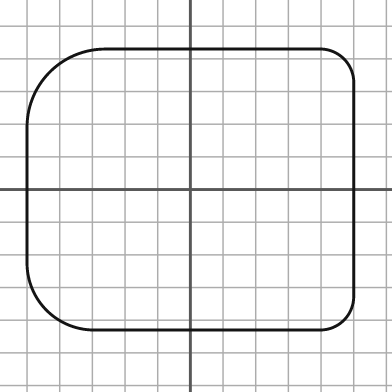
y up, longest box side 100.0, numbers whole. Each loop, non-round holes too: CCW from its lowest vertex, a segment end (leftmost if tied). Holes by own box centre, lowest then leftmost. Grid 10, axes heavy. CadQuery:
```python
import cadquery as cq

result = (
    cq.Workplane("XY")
    .moveTo(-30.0, -43.0)
    .lineTo(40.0, -43.0)
    .threePointArc((47.0, -40.0), (50.0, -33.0))
    .lineTo(50.0, 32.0)
    .threePointArc((47.0, 40.0), (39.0, 43.0))
    .lineTo(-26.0, 43.0)
    .threePointArc((-43.0, 36.0), (-50.0, 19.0))
    .lineTo(-50.0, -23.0)
    .threePointArc((-44.0, -37.0), (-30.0, -43.0))
    .close()
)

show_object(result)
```